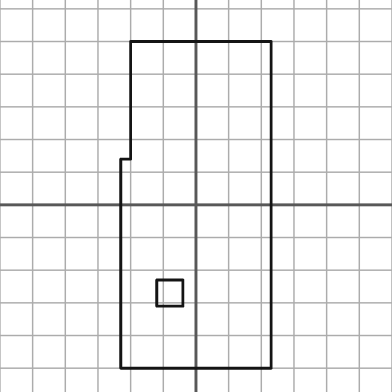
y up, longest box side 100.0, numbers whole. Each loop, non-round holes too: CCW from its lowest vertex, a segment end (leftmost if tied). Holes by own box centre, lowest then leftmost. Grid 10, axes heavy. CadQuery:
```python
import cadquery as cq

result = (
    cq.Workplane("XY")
    .moveTo(-23.0, -50.0)
    .lineTo(23.0, -50.0)
    .lineTo(23.0, 50.0)
    .lineTo(-20.0, 50.0)
    .lineTo(-20.0, 14.0)
    .lineTo(-23.0, 14.0)
    .close()
    .moveTo(-12.0, -31.0)
    .lineTo(-4.0, -31.0)
    .lineTo(-4.0, -23.0)
    .lineTo(-12.0, -23.0)
    .close()
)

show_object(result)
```